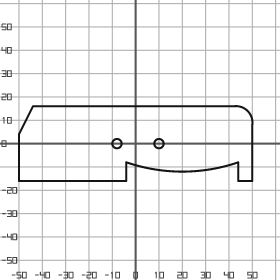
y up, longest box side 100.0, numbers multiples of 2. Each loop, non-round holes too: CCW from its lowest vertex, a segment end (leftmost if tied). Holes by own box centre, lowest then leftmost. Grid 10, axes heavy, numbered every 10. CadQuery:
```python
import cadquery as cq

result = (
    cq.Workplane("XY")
    .moveTo(-50.0, -16.0)
    .lineTo(-4.0, -16.0)
    .lineTo(-4.0, -8.0)
    .threePointArc((20.0, -12.0), (44.0, -8.0))
    .lineTo(44.0, -16.0)
    .lineTo(50.0, -16.0)
    .lineTo(50.0, 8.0)
    .threePointArc((48.0, 14.0), (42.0, 16.0))
    .lineTo(-44.0, 16.0)
    .lineTo(-50.0, 4.0)
    .close()
    .moveTo(-8.0, 0.0)
    .circle(2.0)
    .moveTo(10.0, 0.0)
    .circle(2.0)
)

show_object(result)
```